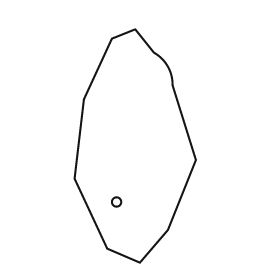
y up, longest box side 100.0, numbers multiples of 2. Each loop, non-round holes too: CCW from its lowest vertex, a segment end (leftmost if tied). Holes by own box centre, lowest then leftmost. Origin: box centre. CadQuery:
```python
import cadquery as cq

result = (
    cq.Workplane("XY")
    .moveTo(2.0, -50.0)
    .lineTo(14.0, -36.0)
    .lineTo(26.0, -6.0)
    .lineTo(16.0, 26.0)
    .threePointArc((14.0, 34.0), (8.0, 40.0))
    .lineTo(0.0, 50.0)
    .lineTo(-10.0, 46.0)
    .lineTo(-22.0, 20.0)
    .lineTo(-26.0, -14.0)
    .lineTo(-12.0, -44.0)
    .close()
    .moveTo(-8.0, -24.0)
    .circle(2.0)
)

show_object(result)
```